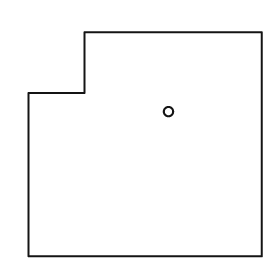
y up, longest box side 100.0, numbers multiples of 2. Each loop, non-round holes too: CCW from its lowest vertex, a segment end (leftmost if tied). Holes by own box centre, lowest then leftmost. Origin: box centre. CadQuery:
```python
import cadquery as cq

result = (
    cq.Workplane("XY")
    .moveTo(-50.0, -48.0)
    .lineTo(50.0, -48.0)
    .lineTo(50.0, 48.0)
    .lineTo(-26.0, 48.0)
    .lineTo(-26.0, 22.0)
    .lineTo(-50.0, 22.0)
    .close()
    .moveTo(10.0, 14.0)
    .circle(2.0)
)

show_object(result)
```